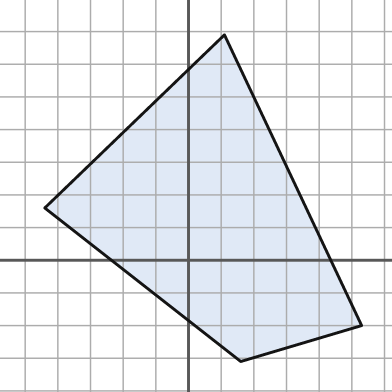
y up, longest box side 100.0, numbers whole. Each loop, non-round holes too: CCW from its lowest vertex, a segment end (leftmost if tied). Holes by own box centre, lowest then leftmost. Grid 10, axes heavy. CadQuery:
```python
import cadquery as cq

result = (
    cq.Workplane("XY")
    .moveTo(16.0, -31.0)
    .lineTo(53.0, -20.0)
    .lineTo(11.0, 69.0)
    .lineTo(-44.0, 16.0)
    .close()
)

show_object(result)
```